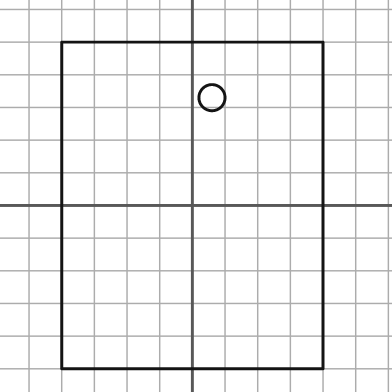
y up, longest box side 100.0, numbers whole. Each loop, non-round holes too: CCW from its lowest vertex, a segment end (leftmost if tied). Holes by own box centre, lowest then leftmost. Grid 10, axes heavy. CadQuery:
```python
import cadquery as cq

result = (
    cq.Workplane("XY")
    .moveTo(-40.0, -50.0)
    .lineTo(40.0, -50.0)
    .lineTo(40.0, 50.0)
    .lineTo(-40.0, 50.0)
    .close()
    .moveTo(6.0, 33.0)
    .circle(4.0)
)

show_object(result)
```